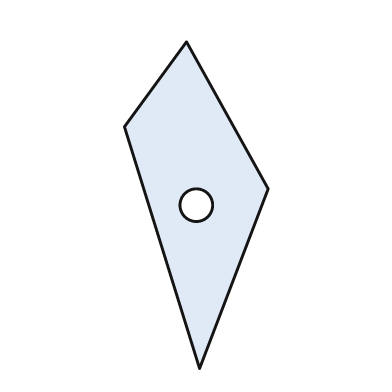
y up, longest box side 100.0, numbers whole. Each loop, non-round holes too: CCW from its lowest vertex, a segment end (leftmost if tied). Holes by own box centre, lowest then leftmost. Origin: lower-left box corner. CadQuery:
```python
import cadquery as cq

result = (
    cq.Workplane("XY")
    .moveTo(23.0, 0.0)
    .lineTo(44.0, 55.0)
    .lineTo(19.0, 100.0)
    .lineTo(0.0, 74.0)
    .close()
    .moveTo(22.0, 50.0)
    .circle(5.0)
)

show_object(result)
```